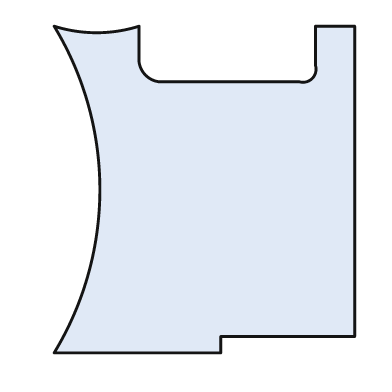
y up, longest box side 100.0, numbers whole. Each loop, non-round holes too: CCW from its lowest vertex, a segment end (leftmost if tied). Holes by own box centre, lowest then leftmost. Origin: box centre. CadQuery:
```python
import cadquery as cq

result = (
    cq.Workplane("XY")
    .moveTo(-46.0, -50.0)
    .lineTo(5.0, -50.0)
    .lineTo(5.0, -45.0)
    .lineTo(46.0, -45.0)
    .lineTo(46.0, 50.0)
    .lineTo(34.0, 50.0)
    .lineTo(34.0, 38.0)
    .threePointArc((33.0, 34.0), (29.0, 33.0))
    .lineTo(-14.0, 33.0)
    .threePointArc((-18.0, 35.0), (-20.0, 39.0))
    .lineTo(-20.0, 50.0)
    .threePointArc((-33.0, 48.0), (-46.0, 50.0))
    .threePointArc((-32.0, 0.0), (-46.0, -50.0))
    .close()
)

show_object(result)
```